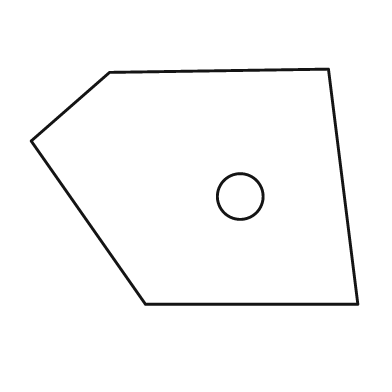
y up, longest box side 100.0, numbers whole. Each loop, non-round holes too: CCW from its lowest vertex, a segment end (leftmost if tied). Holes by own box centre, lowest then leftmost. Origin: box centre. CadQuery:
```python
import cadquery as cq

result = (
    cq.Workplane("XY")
    .moveTo(-15.0, -36.0)
    .lineTo(50.0, -36.0)
    .lineTo(41.0, 36.0)
    .lineTo(-26.0, 35.0)
    .lineTo(-50.0, 14.0)
    .close()
    .moveTo(14.0, -3.0)
    .circle(7.0)
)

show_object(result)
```